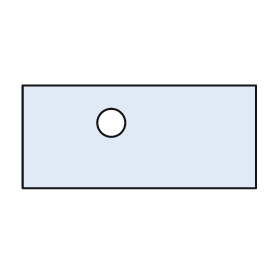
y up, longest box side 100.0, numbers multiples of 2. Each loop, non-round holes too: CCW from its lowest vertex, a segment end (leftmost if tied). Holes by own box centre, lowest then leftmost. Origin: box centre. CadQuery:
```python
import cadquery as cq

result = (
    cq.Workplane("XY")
    .moveTo(-50.0, -22.0)
    .lineTo(50.0, -22.0)
    .lineTo(50.0, 22.0)
    .lineTo(-50.0, 22.0)
    .close()
    .moveTo(-12.0, 6.0)
    .circle(6.0)
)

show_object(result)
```